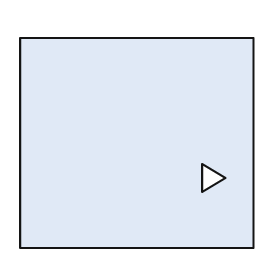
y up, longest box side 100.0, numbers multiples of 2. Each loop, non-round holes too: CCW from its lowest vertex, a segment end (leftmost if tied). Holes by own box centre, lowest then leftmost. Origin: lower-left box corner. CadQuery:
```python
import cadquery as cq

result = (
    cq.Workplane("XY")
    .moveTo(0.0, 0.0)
    .lineTo(100.0, 0.0)
    .lineTo(100.0, 90.0)
    .lineTo(0.0, 90.0)
    .close()
    .moveTo(78.0, 24.0)
    .lineTo(88.0, 30.0)
    .lineTo(78.0, 36.0)
    .close()
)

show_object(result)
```